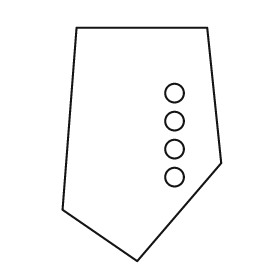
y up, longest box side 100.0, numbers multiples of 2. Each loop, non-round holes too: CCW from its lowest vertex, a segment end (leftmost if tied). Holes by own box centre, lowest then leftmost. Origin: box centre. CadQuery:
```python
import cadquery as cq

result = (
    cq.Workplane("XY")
    .moveTo(-2.0, -50.0)
    .lineTo(34.0, -8.0)
    .lineTo(28.0, 50.0)
    .lineTo(-28.0, 50.0)
    .lineTo(-34.0, -28.0)
    .close()
    .moveTo(14.0, -14.0)
    .circle(4.0)
    .moveTo(14.0, -2.0)
    .circle(4.0)
    .moveTo(14.0, 10.0)
    .circle(4.0)
    .moveTo(14.0, 22.0)
    .circle(4.0)
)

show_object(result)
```